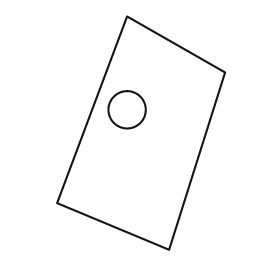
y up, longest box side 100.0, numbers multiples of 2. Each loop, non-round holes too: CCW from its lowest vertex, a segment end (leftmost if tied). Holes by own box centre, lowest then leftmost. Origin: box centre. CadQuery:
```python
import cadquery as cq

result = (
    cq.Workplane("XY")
    .moveTo(12.0, -50.0)
    .lineTo(36.0, 26.0)
    .lineTo(-6.0, 50.0)
    .lineTo(-36.0, -30.0)
    .close()
    .moveTo(-6.0, 10.0)
    .circle(8.0)
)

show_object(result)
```